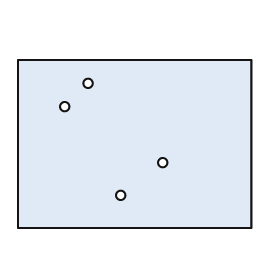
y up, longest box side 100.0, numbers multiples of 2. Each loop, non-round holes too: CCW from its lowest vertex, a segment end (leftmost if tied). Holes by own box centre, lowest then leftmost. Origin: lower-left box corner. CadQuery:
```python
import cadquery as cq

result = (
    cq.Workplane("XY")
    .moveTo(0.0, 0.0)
    .lineTo(100.0, 0.0)
    .lineTo(100.0, 72.0)
    .lineTo(0.0, 72.0)
    .close()
    .moveTo(44.0, 14.0)
    .circle(2.0)
    .moveTo(62.0, 28.0)
    .circle(2.0)
    .moveTo(20.0, 52.0)
    .circle(2.0)
    .moveTo(30.0, 62.0)
    .circle(2.0)
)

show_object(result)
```